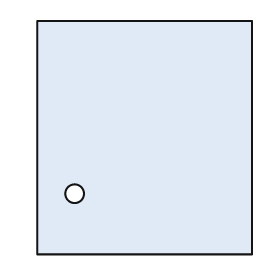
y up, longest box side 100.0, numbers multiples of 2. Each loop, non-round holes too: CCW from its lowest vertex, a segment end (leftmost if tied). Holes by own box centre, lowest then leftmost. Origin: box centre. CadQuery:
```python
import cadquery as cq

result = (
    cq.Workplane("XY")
    .moveTo(-46.0, -50.0)
    .lineTo(46.0, -50.0)
    .lineTo(46.0, 50.0)
    .lineTo(-46.0, 50.0)
    .close()
    .moveTo(-30.0, -24.0)
    .circle(4.0)
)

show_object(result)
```